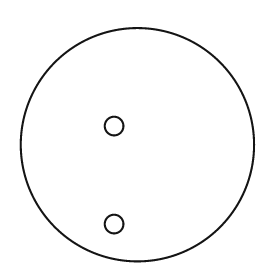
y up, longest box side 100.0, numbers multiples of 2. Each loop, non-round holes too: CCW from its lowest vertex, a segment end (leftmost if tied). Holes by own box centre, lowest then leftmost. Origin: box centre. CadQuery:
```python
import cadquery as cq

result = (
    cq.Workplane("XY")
    .moveTo(0.0, 0.0)
    .circle(50.0)
    .moveTo(-10.0, -34.0)
    .circle(4.0)
    .moveTo(-10.0, 8.0)
    .circle(4.0)
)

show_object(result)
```